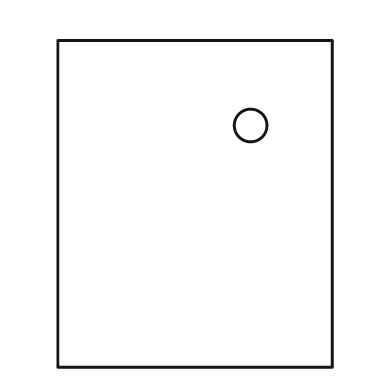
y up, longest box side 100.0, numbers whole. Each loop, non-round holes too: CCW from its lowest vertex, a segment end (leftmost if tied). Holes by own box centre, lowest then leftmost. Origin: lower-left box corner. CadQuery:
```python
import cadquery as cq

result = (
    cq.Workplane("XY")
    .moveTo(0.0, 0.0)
    .lineTo(84.0, 0.0)
    .lineTo(84.0, 100.0)
    .lineTo(0.0, 100.0)
    .close()
    .moveTo(59.0, 74.0)
    .circle(5.0)
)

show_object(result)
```